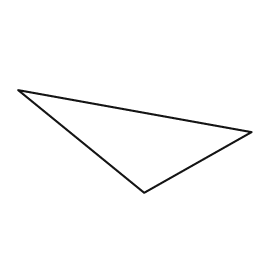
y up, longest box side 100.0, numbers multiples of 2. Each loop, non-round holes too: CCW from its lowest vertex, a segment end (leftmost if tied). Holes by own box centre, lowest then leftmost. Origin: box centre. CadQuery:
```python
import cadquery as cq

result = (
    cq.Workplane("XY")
    .moveTo(4.0, -22.0)
    .lineTo(50.0, 4.0)
    .lineTo(-50.0, 22.0)
    .close()
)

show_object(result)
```